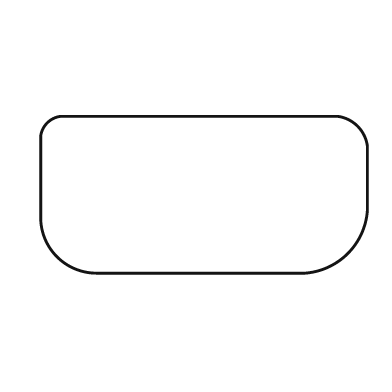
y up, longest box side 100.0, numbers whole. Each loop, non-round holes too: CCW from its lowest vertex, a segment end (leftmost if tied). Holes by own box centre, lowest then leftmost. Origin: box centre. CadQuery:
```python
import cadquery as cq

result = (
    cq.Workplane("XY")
    .moveTo(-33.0, -24.0)
    .lineTo(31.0, -24.0)
    .threePointArc((44.0, -18.0), (50.0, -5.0))
    .lineTo(50.0, 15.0)
    .threePointArc((47.0, 21.0), (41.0, 24.0))
    .lineTo(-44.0, 24.0)
    .threePointArc((-48.0, 22.0), (-50.0, 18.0))
    .lineTo(-50.0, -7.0)
    .threePointArc((-45.0, -19.0), (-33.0, -24.0))
    .close()
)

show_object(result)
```